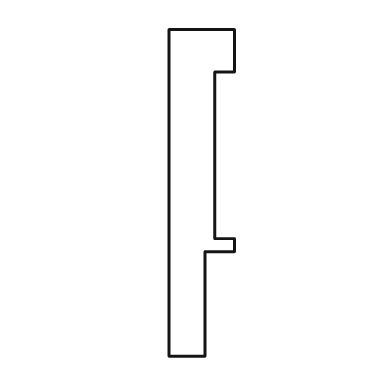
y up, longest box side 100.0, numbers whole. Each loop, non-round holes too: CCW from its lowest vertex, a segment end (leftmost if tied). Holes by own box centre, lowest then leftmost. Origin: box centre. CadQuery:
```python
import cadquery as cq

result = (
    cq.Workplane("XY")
    .moveTo(-10.0, -50.0)
    .lineTo(1.0, -50.0)
    .lineTo(1.0, -18.0)
    .lineTo(10.0, -18.0)
    .lineTo(10.0, -14.0)
    .lineTo(4.0, -14.0)
    .lineTo(4.0, 37.0)
    .lineTo(10.0, 37.0)
    .lineTo(10.0, 50.0)
    .lineTo(-10.0, 50.0)
    .close()
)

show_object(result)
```